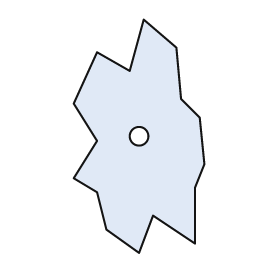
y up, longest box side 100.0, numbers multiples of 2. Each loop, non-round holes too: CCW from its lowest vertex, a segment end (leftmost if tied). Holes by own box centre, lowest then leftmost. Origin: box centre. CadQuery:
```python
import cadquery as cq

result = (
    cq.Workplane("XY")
    .moveTo(0.0, -50.0)
    .lineTo(6.0, -34.0)
    .lineTo(24.0, -46.0)
    .lineTo(24.0, -22.0)
    .lineTo(28.0, -12.0)
    .lineTo(26.0, 8.0)
    .lineTo(18.0, 16.0)
    .lineTo(16.0, 38.0)
    .lineTo(2.0, 50.0)
    .lineTo(-4.0, 28.0)
    .lineTo(-18.0, 36.0)
    .lineTo(-28.0, 14.0)
    .lineTo(-18.0, -2.0)
    .lineTo(-28.0, -18.0)
    .lineTo(-18.0, -24.0)
    .lineTo(-14.0, -40.0)
    .close()
    .moveTo(0.0, 0.0)
    .circle(4.0)
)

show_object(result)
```